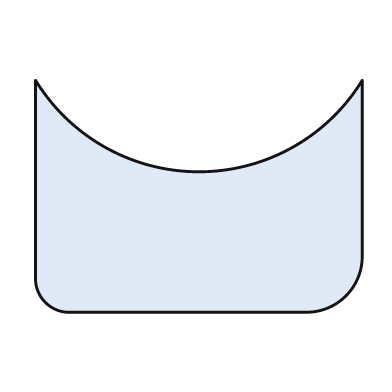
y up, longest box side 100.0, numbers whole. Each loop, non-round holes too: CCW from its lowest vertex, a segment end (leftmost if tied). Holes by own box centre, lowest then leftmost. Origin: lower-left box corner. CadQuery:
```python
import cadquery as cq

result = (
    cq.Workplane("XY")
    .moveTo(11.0, 0.0)
    .lineTo(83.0, 0.0)
    .threePointArc((95.0, 5.0), (100.0, 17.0))
    .lineTo(100.0, 71.0)
    .threePointArc((50.0, 43.0), (0.0, 71.0))
    .lineTo(0.0, 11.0)
    .threePointArc((3.0, 3.0), (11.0, 0.0))
    .close()
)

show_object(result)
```